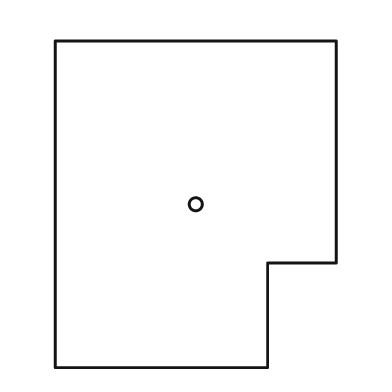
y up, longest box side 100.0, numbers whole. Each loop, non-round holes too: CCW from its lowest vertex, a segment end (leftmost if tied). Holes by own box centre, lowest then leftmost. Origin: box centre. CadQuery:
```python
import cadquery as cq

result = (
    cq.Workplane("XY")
    .moveTo(-43.0, -50.0)
    .lineTo(22.0, -50.0)
    .lineTo(22.0, -18.0)
    .lineTo(43.0, -18.0)
    .lineTo(43.0, 50.0)
    .lineTo(-43.0, 50.0)
    .close()
    .moveTo(0.0, 0.0)
    .circle(2.0)
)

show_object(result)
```